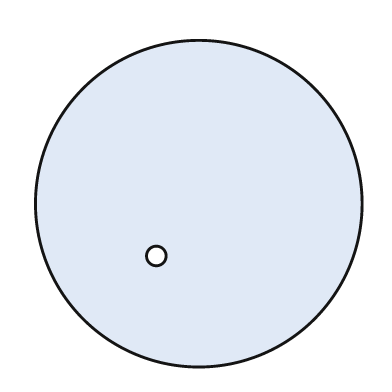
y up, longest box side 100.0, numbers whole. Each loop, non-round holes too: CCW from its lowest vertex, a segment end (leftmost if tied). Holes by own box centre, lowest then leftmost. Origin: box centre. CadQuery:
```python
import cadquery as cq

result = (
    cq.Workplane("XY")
    .moveTo(0.0, 0.0)
    .circle(50.0)
    .moveTo(-13.0, -16.0)
    .circle(3.0)
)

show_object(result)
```